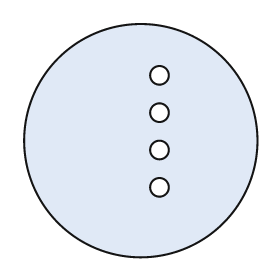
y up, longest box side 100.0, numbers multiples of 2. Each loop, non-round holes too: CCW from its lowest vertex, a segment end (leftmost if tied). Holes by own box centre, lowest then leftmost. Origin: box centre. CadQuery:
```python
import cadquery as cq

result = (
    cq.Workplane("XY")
    .moveTo(0.0, 0.0)
    .circle(50.0)
    .moveTo(8.0, -20.0)
    .circle(4.0)
    .moveTo(8.0, -4.0)
    .circle(4.0)
    .moveTo(8.0, 12.0)
    .circle(4.0)
    .moveTo(8.0, 28.0)
    .circle(4.0)
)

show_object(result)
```